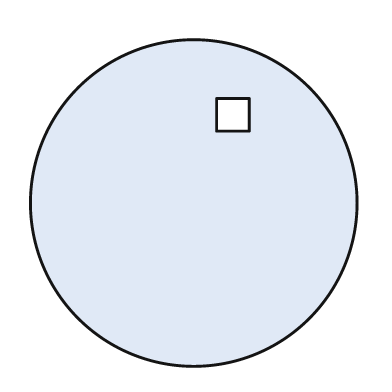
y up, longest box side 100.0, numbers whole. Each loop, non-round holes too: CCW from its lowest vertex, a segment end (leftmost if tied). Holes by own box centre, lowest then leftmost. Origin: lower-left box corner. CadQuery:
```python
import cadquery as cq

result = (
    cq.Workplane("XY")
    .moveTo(50.0, 50.0)
    .circle(50.0)
    .moveTo(57.0, 72.0)
    .lineTo(67.0, 72.0)
    .lineTo(67.0, 82.0)
    .lineTo(57.0, 82.0)
    .close()
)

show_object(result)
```